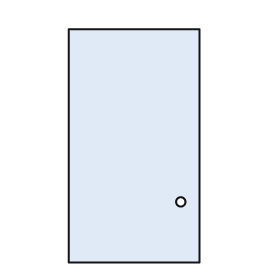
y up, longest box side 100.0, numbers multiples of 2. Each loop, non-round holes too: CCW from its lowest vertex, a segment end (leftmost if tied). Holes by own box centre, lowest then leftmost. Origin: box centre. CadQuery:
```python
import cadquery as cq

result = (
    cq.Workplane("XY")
    .moveTo(-28.0, -50.0)
    .lineTo(28.0, -50.0)
    .lineTo(28.0, 50.0)
    .lineTo(-28.0, 50.0)
    .close()
    .moveTo(20.0, -24.0)
    .circle(2.0)
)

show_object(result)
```